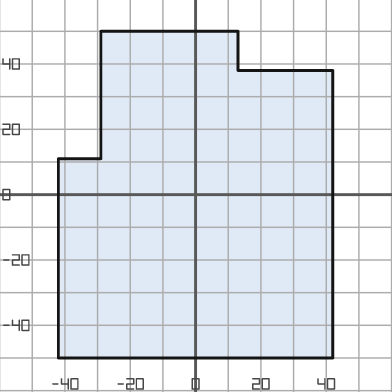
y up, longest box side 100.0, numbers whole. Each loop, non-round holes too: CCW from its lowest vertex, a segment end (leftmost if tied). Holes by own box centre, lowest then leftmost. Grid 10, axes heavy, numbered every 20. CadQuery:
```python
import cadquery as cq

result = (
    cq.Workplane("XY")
    .moveTo(-42.0, -50.0)
    .lineTo(42.0, -50.0)
    .lineTo(42.0, 38.0)
    .lineTo(13.0, 38.0)
    .lineTo(13.0, 50.0)
    .lineTo(-29.0, 50.0)
    .lineTo(-29.0, 11.0)
    .lineTo(-42.0, 11.0)
    .close()
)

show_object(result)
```